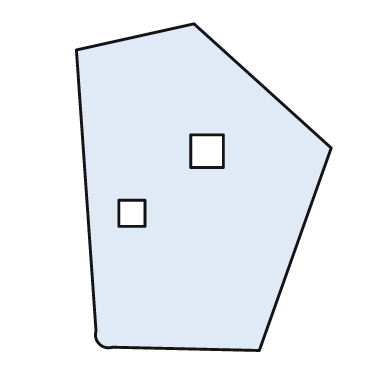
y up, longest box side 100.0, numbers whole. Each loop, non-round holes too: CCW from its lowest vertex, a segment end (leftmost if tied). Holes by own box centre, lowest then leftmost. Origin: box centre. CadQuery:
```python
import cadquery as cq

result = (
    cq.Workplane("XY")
    .moveTo(17.0, -50.0)
    .lineTo(39.0, 12.0)
    .lineTo(-3.0, 50.0)
    .lineTo(-39.0, 42.0)
    .lineTo(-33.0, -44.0)
    .threePointArc((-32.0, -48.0), (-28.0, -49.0))
    .close()
    .moveTo(-26.0, -12.0)
    .lineTo(-18.0, -12.0)
    .lineTo(-18.0, -4.0)
    .lineTo(-26.0, -4.0)
    .close()
    .moveTo(-4.0, 6.0)
    .lineTo(6.0, 6.0)
    .lineTo(6.0, 16.0)
    .lineTo(-4.0, 16.0)
    .close()
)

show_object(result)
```